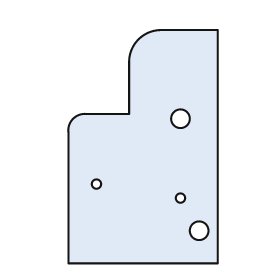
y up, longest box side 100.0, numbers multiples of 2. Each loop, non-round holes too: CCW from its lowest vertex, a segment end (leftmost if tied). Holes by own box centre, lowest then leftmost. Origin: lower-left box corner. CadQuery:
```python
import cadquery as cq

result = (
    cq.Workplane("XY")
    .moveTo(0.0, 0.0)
    .lineTo(64.0, 0.0)
    .lineTo(64.0, 100.0)
    .lineTo(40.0, 100.0)
    .threePointArc((30.0, 96.0), (26.0, 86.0))
    .lineTo(26.0, 64.0)
    .lineTo(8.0, 64.0)
    .threePointArc((2.0, 62.0), (0.0, 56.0))
    .close()
    .moveTo(56.0, 14.0)
    .circle(4.0)
    .moveTo(48.0, 28.0)
    .circle(2.0)
    .moveTo(12.0, 34.0)
    .circle(2.0)
    .moveTo(48.0, 62.0)
    .circle(4.0)
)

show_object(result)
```